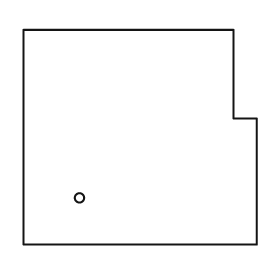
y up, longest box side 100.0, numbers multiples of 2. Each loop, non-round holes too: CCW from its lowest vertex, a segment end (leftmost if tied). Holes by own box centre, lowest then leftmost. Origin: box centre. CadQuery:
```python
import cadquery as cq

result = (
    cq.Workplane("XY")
    .moveTo(-50.0, -46.0)
    .lineTo(50.0, -46.0)
    .lineTo(50.0, 8.0)
    .lineTo(40.0, 8.0)
    .lineTo(40.0, 46.0)
    .lineTo(-50.0, 46.0)
    .close()
    .moveTo(-26.0, -26.0)
    .circle(2.0)
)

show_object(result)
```